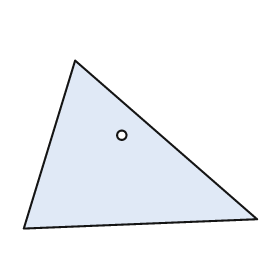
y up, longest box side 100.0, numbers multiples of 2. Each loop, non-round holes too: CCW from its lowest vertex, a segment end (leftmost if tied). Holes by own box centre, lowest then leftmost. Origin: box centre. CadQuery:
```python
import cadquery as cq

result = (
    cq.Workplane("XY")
    .moveTo(-50.0, -36.0)
    .lineTo(50.0, -32.0)
    .lineTo(-28.0, 36.0)
    .close()
    .moveTo(-8.0, 4.0)
    .circle(2.0)
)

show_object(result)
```